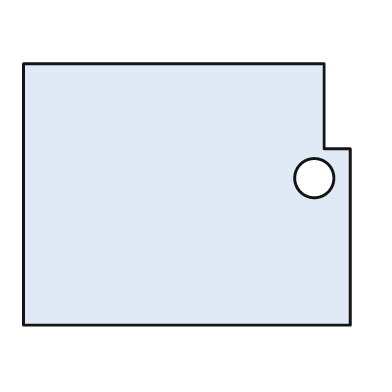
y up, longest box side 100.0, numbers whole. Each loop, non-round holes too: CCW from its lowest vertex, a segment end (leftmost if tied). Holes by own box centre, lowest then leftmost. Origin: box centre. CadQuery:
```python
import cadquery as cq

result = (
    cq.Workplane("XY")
    .moveTo(-50.0, -40.0)
    .lineTo(50.0, -40.0)
    .lineTo(50.0, 14.0)
    .lineTo(42.0, 14.0)
    .lineTo(42.0, 40.0)
    .lineTo(-50.0, 40.0)
    .close()
    .moveTo(39.0, 5.0)
    .circle(6.0)
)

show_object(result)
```